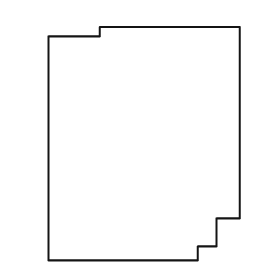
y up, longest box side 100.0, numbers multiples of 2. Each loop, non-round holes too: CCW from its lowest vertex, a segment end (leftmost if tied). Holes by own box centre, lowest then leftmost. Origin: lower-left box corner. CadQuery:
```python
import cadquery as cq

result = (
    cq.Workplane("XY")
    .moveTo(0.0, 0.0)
    .lineTo(64.0, 0.0)
    .lineTo(64.0, 6.0)
    .lineTo(72.0, 6.0)
    .lineTo(72.0, 18.0)
    .lineTo(82.0, 18.0)
    .lineTo(82.0, 100.0)
    .lineTo(22.0, 100.0)
    .lineTo(22.0, 96.0)
    .lineTo(0.0, 96.0)
    .close()
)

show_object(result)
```